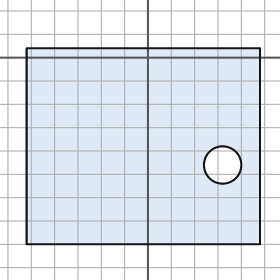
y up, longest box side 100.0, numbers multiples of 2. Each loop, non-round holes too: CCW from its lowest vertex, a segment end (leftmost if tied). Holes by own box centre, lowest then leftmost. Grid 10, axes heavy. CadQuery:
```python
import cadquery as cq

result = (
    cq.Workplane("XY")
    .moveTo(-52.0, -80.0)
    .lineTo(48.0, -80.0)
    .lineTo(48.0, 4.0)
    .lineTo(-52.0, 4.0)
    .close()
    .moveTo(32.0, -46.0)
    .circle(8.0)
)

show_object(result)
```